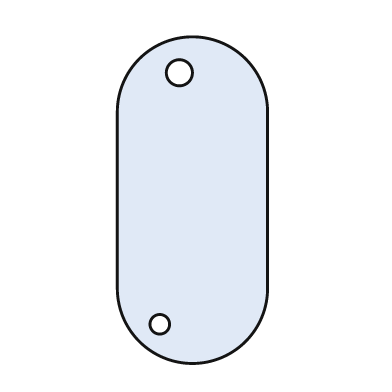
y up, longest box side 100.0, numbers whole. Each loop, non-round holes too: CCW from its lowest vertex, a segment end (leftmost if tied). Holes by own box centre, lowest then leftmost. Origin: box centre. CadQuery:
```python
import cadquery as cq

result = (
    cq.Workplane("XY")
    .moveTo(-23.0, -27.0)
    .threePointArc((0.0, -50.0), (23.0, -27.0))
    .lineTo(23.0, 27.0)
    .threePointArc((0.0, 50.0), (-23.0, 27.0))
    .close()
    .moveTo(-10.0, -38.0)
    .circle(3.0)
    .moveTo(-4.0, 39.0)
    .circle(4.0)
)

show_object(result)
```